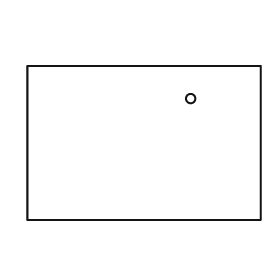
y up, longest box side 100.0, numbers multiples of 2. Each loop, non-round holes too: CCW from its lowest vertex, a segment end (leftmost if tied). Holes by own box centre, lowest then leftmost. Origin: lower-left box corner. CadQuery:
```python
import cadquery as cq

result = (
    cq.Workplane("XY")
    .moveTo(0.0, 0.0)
    .lineTo(100.0, 0.0)
    .lineTo(100.0, 66.0)
    .lineTo(0.0, 66.0)
    .close()
    .moveTo(70.0, 52.0)
    .circle(2.0)
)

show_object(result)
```